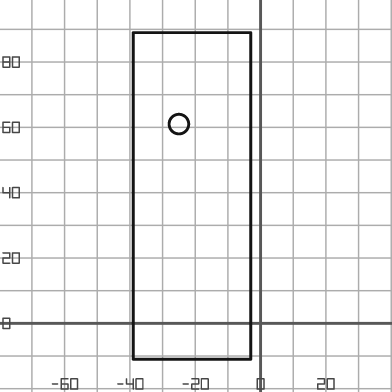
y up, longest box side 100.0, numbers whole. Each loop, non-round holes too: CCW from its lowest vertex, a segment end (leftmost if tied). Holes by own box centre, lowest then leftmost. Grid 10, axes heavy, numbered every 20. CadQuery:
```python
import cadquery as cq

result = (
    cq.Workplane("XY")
    .moveTo(-39.0, -11.0)
    .lineTo(-3.0, -11.0)
    .lineTo(-3.0, 89.0)
    .lineTo(-39.0, 89.0)
    .close()
    .moveTo(-25.0, 61.0)
    .circle(3.0)
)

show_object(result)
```